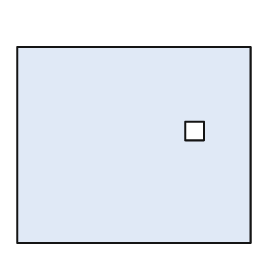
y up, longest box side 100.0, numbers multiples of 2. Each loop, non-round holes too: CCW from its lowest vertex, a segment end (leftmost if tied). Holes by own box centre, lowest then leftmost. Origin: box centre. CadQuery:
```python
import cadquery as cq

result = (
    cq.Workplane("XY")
    .moveTo(-50.0, -42.0)
    .lineTo(50.0, -42.0)
    .lineTo(50.0, 42.0)
    .lineTo(-50.0, 42.0)
    .close()
    .moveTo(22.0, 2.0)
    .lineTo(30.0, 2.0)
    .lineTo(30.0, 10.0)
    .lineTo(22.0, 10.0)
    .close()
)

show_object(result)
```